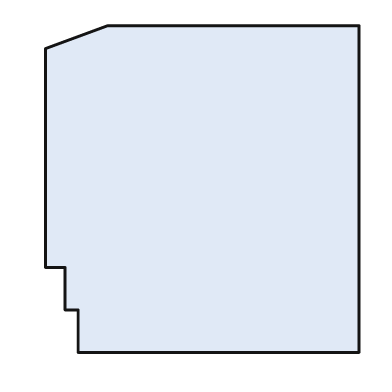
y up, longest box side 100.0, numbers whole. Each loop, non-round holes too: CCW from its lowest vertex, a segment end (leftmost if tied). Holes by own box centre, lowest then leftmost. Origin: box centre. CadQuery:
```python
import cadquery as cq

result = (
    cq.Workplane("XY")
    .moveTo(-38.0, -50.0)
    .lineTo(48.0, -50.0)
    .lineTo(48.0, 50.0)
    .lineTo(-29.0, 50.0)
    .lineTo(-48.0, 43.0)
    .lineTo(-48.0, -24.0)
    .lineTo(-42.0, -24.0)
    .lineTo(-42.0, -37.0)
    .lineTo(-38.0, -37.0)
    .close()
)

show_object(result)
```